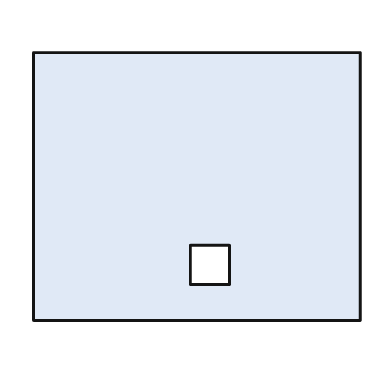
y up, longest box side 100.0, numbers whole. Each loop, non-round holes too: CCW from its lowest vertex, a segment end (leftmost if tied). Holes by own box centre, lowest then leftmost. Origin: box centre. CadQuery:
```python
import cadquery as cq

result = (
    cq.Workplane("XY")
    .moveTo(-50.0, -41.0)
    .lineTo(50.0, -41.0)
    .lineTo(50.0, 41.0)
    .lineTo(-50.0, 41.0)
    .close()
    .moveTo(-2.0, -30.0)
    .lineTo(10.0, -30.0)
    .lineTo(10.0, -18.0)
    .lineTo(-2.0, -18.0)
    .close()
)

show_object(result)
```